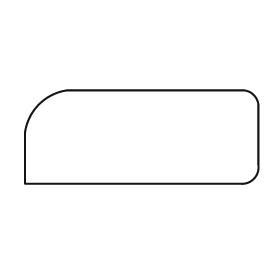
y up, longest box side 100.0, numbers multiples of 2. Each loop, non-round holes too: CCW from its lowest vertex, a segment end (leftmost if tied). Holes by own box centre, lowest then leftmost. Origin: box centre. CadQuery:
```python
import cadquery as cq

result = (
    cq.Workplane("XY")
    .moveTo(-50.0, -20.0)
    .lineTo(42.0, -20.0)
    .threePointArc((48.0, -18.0), (50.0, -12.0))
    .lineTo(50.0, 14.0)
    .threePointArc((48.0, 18.0), (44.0, 20.0))
    .lineTo(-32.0, 20.0)
    .threePointArc((-44.0, 14.0), (-50.0, 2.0))
    .close()
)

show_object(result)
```